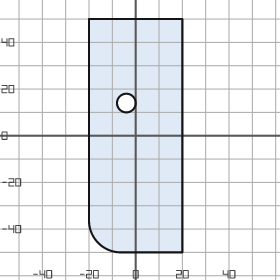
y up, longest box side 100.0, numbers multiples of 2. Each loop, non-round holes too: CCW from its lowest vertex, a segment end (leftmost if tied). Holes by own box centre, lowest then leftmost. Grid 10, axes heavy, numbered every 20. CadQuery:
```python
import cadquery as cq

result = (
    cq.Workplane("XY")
    .moveTo(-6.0, -50.0)
    .lineTo(20.0, -50.0)
    .lineTo(20.0, 50.0)
    .lineTo(-20.0, 50.0)
    .lineTo(-20.0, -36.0)
    .threePointArc((-16.0, -46.0), (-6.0, -50.0))
    .close()
    .moveTo(-4.0, 14.0)
    .circle(4.0)
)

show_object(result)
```